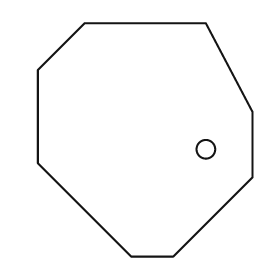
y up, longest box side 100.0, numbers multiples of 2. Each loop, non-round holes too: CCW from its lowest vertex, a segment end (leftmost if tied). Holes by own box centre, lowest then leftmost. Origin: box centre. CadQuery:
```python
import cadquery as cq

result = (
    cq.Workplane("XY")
    .moveTo(-6.0, -50.0)
    .lineTo(12.0, -50.0)
    .lineTo(46.0, -16.0)
    .lineTo(46.0, 12.0)
    .lineTo(26.0, 50.0)
    .lineTo(-26.0, 50.0)
    .lineTo(-46.0, 30.0)
    .lineTo(-46.0, -10.0)
    .close()
    .moveTo(26.0, -4.0)
    .circle(4.0)
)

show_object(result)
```